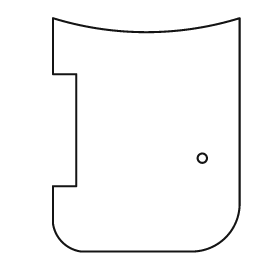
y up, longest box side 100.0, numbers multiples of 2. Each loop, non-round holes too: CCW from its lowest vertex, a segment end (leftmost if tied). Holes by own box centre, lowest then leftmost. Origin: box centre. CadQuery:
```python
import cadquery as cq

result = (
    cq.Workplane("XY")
    .moveTo(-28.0, -50.0)
    .lineTo(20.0, -50.0)
    .threePointArc((34.0, -44.0), (40.0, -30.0))
    .lineTo(40.0, 50.0)
    .threePointArc((0.0, 44.0), (-40.0, 50.0))
    .lineTo(-40.0, 26.0)
    .lineTo(-30.0, 26.0)
    .lineTo(-30.0, -22.0)
    .lineTo(-40.0, -22.0)
    .lineTo(-40.0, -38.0)
    .threePointArc((-36.0, -46.0), (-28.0, -50.0))
    .close()
    .moveTo(24.0, -10.0)
    .circle(2.0)
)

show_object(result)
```